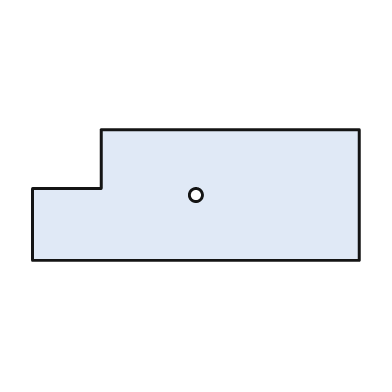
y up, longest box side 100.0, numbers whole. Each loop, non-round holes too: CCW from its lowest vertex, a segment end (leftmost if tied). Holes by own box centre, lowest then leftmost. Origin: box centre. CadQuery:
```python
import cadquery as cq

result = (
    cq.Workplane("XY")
    .moveTo(-50.0, -20.0)
    .lineTo(50.0, -20.0)
    .lineTo(50.0, 20.0)
    .lineTo(-29.0, 20.0)
    .lineTo(-29.0, 2.0)
    .lineTo(-50.0, 2.0)
    .close()
    .moveTo(0.0, 0.0)
    .circle(2.0)
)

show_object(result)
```